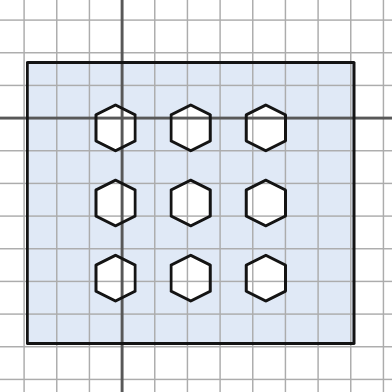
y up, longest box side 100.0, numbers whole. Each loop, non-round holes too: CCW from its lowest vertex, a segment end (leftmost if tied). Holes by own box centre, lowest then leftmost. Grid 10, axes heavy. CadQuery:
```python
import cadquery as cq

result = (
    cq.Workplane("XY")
    .moveTo(-29.0, -69.0)
    .lineTo(71.0, -69.0)
    .lineTo(71.0, 17.0)
    .lineTo(-29.0, 17.0)
    .close()
    .moveTo(-2.0, -56.0)
    .lineTo(4.0, -53.0)
    .lineTo(4.0, -45.0)
    .lineTo(-2.0, -42.0)
    .lineTo(-8.0, -45.0)
    .lineTo(-8.0, -53.0)
    .close()
    .moveTo(21.0, -56.0)
    .lineTo(27.0, -53.0)
    .lineTo(27.0, -45.0)
    .lineTo(21.0, -42.0)
    .lineTo(15.0, -45.0)
    .lineTo(15.0, -53.0)
    .close()
    .moveTo(44.0, -56.0)
    .lineTo(50.0, -53.0)
    .lineTo(50.0, -45.0)
    .lineTo(44.0, -42.0)
    .lineTo(38.0, -45.0)
    .lineTo(38.0, -53.0)
    .close()
    .moveTo(-2.0, -33.0)
    .lineTo(4.0, -30.0)
    .lineTo(4.0, -22.0)
    .lineTo(-2.0, -19.0)
    .lineTo(-8.0, -22.0)
    .lineTo(-8.0, -30.0)
    .close()
    .moveTo(21.0, -33.0)
    .lineTo(27.0, -30.0)
    .lineTo(27.0, -22.0)
    .lineTo(21.0, -19.0)
    .lineTo(15.0, -22.0)
    .lineTo(15.0, -30.0)
    .close()
    .moveTo(44.0, -33.0)
    .lineTo(50.0, -30.0)
    .lineTo(50.0, -22.0)
    .lineTo(44.0, -19.0)
    .lineTo(38.0, -22.0)
    .lineTo(38.0, -30.0)
    .close()
    .moveTo(-2.0, -10.0)
    .lineTo(4.0, -7.0)
    .lineTo(4.0, 1.0)
    .lineTo(-2.0, 4.0)
    .lineTo(-8.0, 1.0)
    .lineTo(-8.0, -7.0)
    .close()
    .moveTo(21.0, -10.0)
    .lineTo(27.0, -7.0)
    .lineTo(27.0, 1.0)
    .lineTo(21.0, 4.0)
    .lineTo(15.0, 1.0)
    .lineTo(15.0, -7.0)
    .close()
    .moveTo(44.0, -10.0)
    .lineTo(50.0, -7.0)
    .lineTo(50.0, 1.0)
    .lineTo(44.0, 4.0)
    .lineTo(38.0, 1.0)
    .lineTo(38.0, -7.0)
    .close()
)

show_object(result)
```